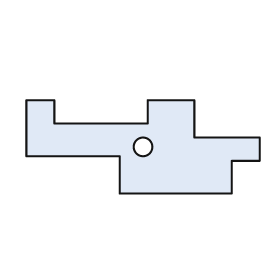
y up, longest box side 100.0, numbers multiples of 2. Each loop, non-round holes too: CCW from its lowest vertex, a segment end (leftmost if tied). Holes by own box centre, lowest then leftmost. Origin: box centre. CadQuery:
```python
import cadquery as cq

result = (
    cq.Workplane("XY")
    .moveTo(-10.0, -20.0)
    .lineTo(38.0, -20.0)
    .lineTo(38.0, -6.0)
    .lineTo(50.0, -6.0)
    .lineTo(50.0, 4.0)
    .lineTo(22.0, 4.0)
    .lineTo(22.0, 20.0)
    .lineTo(2.0, 20.0)
    .lineTo(2.0, 10.0)
    .lineTo(-38.0, 10.0)
    .lineTo(-38.0, 20.0)
    .lineTo(-50.0, 20.0)
    .lineTo(-50.0, -4.0)
    .lineTo(-10.0, -4.0)
    .close()
    .moveTo(0.0, 0.0)
    .circle(4.0)
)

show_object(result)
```